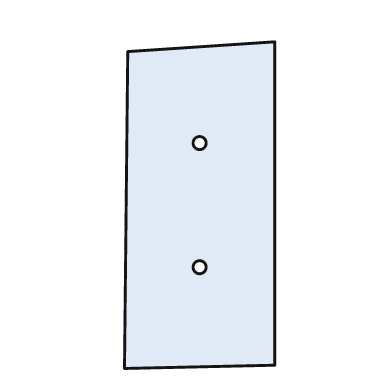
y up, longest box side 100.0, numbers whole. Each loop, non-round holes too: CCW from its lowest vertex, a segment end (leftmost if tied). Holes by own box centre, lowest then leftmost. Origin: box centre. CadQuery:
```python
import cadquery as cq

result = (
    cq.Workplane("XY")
    .moveTo(-23.0, -50.0)
    .lineTo(23.0, -49.0)
    .lineTo(23.0, 50.0)
    .lineTo(-22.0, 47.0)
    .close()
    .moveTo(0.0, -19.0)
    .circle(2.0)
    .moveTo(0.0, 19.0)
    .circle(2.0)
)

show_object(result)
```